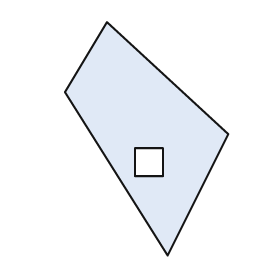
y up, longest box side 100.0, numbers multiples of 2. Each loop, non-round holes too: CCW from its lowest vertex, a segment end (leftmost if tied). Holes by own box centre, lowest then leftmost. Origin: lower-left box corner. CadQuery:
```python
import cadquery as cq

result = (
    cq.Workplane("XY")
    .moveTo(44.0, 0.0)
    .lineTo(70.0, 52.0)
    .lineTo(18.0, 100.0)
    .lineTo(0.0, 70.0)
    .close()
    .moveTo(30.0, 34.0)
    .lineTo(42.0, 34.0)
    .lineTo(42.0, 46.0)
    .lineTo(30.0, 46.0)
    .close()
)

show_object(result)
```